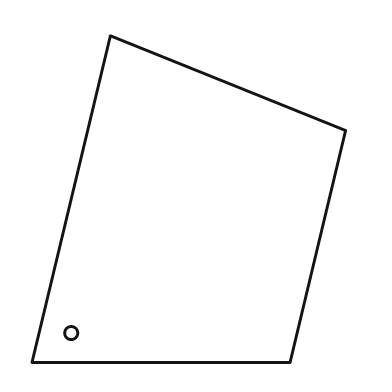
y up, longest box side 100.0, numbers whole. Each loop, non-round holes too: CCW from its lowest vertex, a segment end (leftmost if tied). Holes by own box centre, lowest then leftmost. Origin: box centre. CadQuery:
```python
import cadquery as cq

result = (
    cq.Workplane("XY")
    .moveTo(-48.0, -50.0)
    .lineTo(31.0, -50.0)
    .lineTo(48.0, 21.0)
    .lineTo(-24.0, 50.0)
    .close()
    .moveTo(-36.0, -41.0)
    .circle(2.0)
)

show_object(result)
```